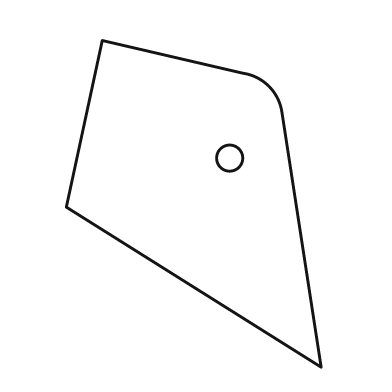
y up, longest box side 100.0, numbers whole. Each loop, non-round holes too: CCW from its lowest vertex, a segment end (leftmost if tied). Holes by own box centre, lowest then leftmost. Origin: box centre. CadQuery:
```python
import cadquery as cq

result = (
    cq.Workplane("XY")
    .moveTo(39.0, -50.0)
    .lineTo(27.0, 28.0)
    .threePointArc((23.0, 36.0), (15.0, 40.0))
    .lineTo(-28.0, 50.0)
    .lineTo(-39.0, -1.0)
    .close()
    .moveTo(11.0, 14.0)
    .circle(4.0)
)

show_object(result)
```